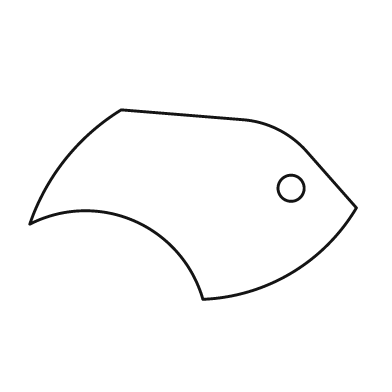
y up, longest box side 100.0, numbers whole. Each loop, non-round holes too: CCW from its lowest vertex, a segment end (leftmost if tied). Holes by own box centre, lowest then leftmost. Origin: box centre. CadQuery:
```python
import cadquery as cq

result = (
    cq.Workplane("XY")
    .moveTo(3.0, -29.0)
    .threePointArc((30.0, -21.0), (50.0, -1.0))
    .lineTo(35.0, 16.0)
    .threePointArc((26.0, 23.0), (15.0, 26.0))
    .lineTo(-22.0, 29.0)
    .threePointArc((-39.0, 14.0), (-50.0, -6.0))
    .threePointArc((-18.0, -5.0), (3.0, -29.0))
    .close()
    .moveTo(30.0, 5.0)
    .circle(4.0)
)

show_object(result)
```